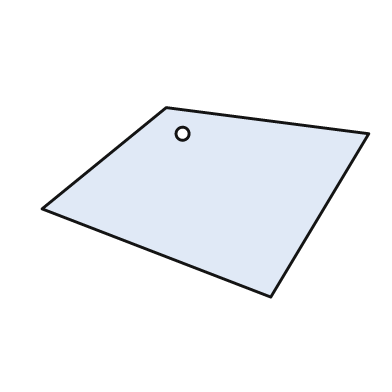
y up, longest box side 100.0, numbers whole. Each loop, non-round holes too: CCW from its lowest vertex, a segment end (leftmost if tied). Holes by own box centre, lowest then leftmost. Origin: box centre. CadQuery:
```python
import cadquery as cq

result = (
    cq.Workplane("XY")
    .moveTo(20.0, -29.0)
    .lineTo(50.0, 21.0)
    .lineTo(-12.0, 29.0)
    .lineTo(-50.0, -2.0)
    .close()
    .moveTo(-7.0, 21.0)
    .circle(2.0)
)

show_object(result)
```